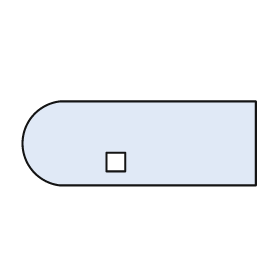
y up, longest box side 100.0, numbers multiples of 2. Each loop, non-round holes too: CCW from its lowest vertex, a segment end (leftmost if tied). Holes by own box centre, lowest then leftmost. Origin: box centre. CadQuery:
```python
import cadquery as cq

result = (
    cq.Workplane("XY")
    .moveTo(-34.0, -18.0)
    .lineTo(50.0, -18.0)
    .lineTo(50.0, 18.0)
    .lineTo(-34.0, 18.0)
    .threePointArc((-50.0, 0.0), (-34.0, -18.0))
    .close()
    .moveTo(-14.0, -12.0)
    .lineTo(-6.0, -12.0)
    .lineTo(-6.0, -4.0)
    .lineTo(-14.0, -4.0)
    .close()
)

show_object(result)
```